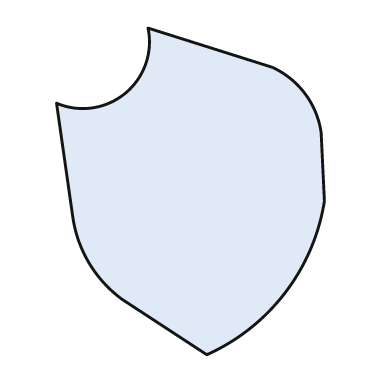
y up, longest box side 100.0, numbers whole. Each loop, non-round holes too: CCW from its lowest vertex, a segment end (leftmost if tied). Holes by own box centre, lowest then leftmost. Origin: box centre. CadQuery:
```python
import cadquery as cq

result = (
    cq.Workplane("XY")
    .moveTo(5.0, -50.0)
    .threePointArc((29.0, -31.0), (41.0, -3.0))
    .lineTo(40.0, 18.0)
    .threePointArc((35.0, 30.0), (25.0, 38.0))
    .lineTo(-13.0, 50.0)
    .threePointArc((-20.0, 30.0), (-41.0, 27.0))
    .lineTo(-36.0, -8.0)
    .threePointArc((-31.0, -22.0), (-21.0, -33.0))
    .close()
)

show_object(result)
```